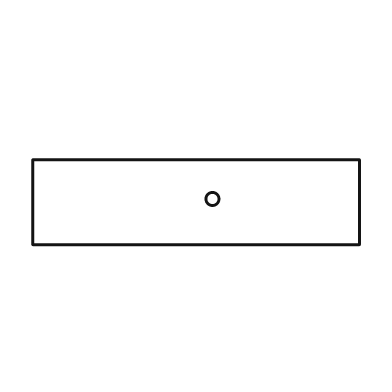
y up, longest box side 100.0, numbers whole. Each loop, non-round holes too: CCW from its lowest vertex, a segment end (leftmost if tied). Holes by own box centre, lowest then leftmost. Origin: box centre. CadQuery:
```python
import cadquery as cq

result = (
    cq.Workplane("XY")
    .moveTo(-50.0, -13.0)
    .lineTo(50.0, -13.0)
    .lineTo(50.0, 13.0)
    .lineTo(-50.0, 13.0)
    .close()
    .moveTo(5.0, 1.0)
    .circle(2.0)
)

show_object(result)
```